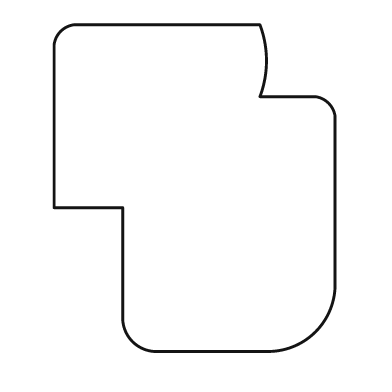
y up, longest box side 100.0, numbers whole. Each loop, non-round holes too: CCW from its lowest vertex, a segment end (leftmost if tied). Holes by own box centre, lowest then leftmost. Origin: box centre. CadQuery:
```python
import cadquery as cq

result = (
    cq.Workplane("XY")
    .moveTo(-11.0, -50.0)
    .lineTo(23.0, -50.0)
    .threePointArc((37.0, -44.0), (43.0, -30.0))
    .lineTo(43.0, 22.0)
    .threePointArc((41.0, 26.0), (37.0, 28.0))
    .lineTo(20.0, 28.0)
    .threePointArc((22.0, 39.0), (20.0, 50.0))
    .lineTo(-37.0, 50.0)
    .threePointArc((-41.0, 48.0), (-43.0, 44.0))
    .lineTo(-43.0, -6.0)
    .lineTo(-22.0, -6.0)
    .lineTo(-22.0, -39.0)
    .threePointArc((-19.0, -47.0), (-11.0, -50.0))
    .close()
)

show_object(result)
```